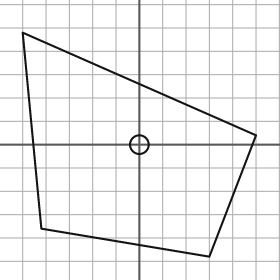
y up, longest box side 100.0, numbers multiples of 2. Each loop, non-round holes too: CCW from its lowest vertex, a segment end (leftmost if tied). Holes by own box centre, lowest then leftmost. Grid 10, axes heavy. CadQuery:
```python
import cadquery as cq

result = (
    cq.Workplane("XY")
    .moveTo(30.0, -48.0)
    .lineTo(50.0, 4.0)
    .lineTo(-50.0, 48.0)
    .lineTo(-42.0, -36.0)
    .close()
    .moveTo(0.0, 0.0)
    .circle(4.0)
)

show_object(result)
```